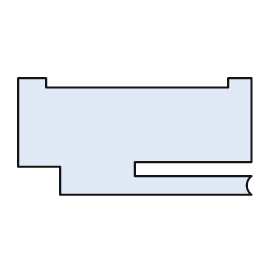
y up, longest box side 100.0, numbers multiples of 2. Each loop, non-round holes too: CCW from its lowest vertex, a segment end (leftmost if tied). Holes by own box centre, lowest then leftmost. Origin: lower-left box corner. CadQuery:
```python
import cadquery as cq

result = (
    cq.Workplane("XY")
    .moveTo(18.0, 0.0)
    .lineTo(100.0, 0.0)
    .threePointArc((98.0, 4.0), (100.0, 8.0))
    .lineTo(50.0, 8.0)
    .lineTo(50.0, 14.0)
    .lineTo(100.0, 14.0)
    .lineTo(100.0, 50.0)
    .lineTo(90.0, 50.0)
    .lineTo(90.0, 46.0)
    .lineTo(12.0, 46.0)
    .lineTo(12.0, 50.0)
    .lineTo(0.0, 50.0)
    .lineTo(0.0, 12.0)
    .lineTo(18.0, 12.0)
    .close()
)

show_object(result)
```